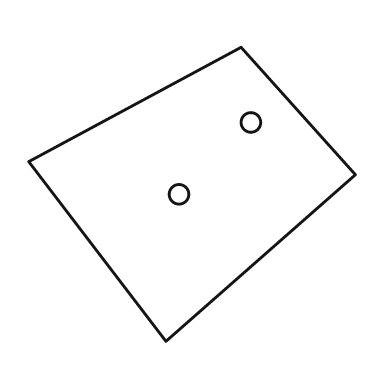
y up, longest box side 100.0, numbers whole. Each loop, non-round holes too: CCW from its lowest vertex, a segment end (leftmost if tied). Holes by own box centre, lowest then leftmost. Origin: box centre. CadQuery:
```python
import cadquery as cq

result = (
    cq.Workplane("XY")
    .moveTo(-8.0, -45.0)
    .lineTo(50.0, 6.0)
    .lineTo(15.0, 45.0)
    .lineTo(-50.0, 10.0)
    .close()
    .moveTo(-4.0, 0.0)
    .circle(3.0)
    .moveTo(18.0, 22.0)
    .circle(3.0)
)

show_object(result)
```